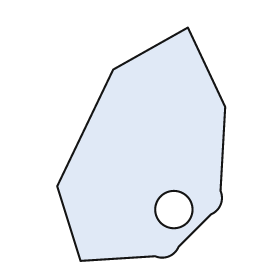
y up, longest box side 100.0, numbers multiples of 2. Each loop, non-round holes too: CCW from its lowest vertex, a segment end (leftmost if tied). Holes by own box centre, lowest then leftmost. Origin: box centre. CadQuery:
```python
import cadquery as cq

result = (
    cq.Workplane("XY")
    .moveTo(-26.0, -50.0)
    .lineTo(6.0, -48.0)
    .threePointArc((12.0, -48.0), (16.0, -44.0))
    .lineTo(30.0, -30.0)
    .threePointArc((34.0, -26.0), (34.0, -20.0))
    .lineTo(36.0, 16.0)
    .lineTo(20.0, 50.0)
    .lineTo(-12.0, 32.0)
    .lineTo(-36.0, -18.0)
    .close()
    .moveTo(14.0, -28.0)
    .circle(8.0)
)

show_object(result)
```